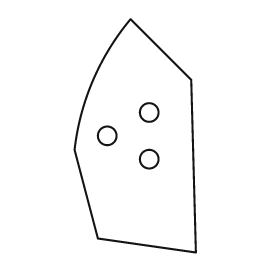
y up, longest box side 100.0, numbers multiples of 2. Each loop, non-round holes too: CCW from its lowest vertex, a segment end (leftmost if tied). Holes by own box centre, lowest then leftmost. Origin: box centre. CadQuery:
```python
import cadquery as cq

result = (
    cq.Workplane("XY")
    .moveTo(26.0, -50.0)
    .lineTo(24.0, 24.0)
    .lineTo(-2.0, 50.0)
    .threePointArc((-18.0, 24.0), (-26.0, -6.0))
    .lineTo(-16.0, -44.0)
    .close()
    .moveTo(6.0, -10.0)
    .circle(4.0)
    .moveTo(-12.0, 0.0)
    .circle(4.0)
    .moveTo(6.0, 10.0)
    .circle(4.0)
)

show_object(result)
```